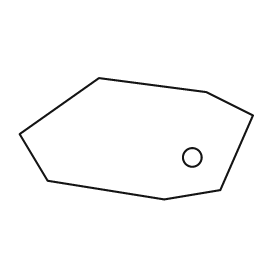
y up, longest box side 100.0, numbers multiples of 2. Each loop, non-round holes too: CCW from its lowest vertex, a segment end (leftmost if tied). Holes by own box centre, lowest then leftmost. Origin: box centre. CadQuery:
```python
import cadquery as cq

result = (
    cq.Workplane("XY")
    .moveTo(12.0, -26.0)
    .lineTo(36.0, -22.0)
    .lineTo(50.0, 10.0)
    .lineTo(30.0, 20.0)
    .lineTo(-16.0, 26.0)
    .lineTo(-50.0, 2.0)
    .lineTo(-38.0, -18.0)
    .close()
    .moveTo(24.0, -8.0)
    .circle(4.0)
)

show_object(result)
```